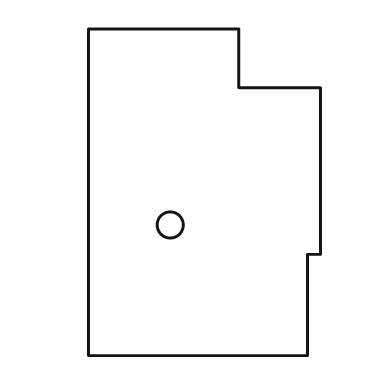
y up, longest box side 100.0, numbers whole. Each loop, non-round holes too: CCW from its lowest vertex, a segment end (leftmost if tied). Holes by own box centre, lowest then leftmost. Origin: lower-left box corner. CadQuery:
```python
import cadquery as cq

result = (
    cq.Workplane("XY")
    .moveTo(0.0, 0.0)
    .lineTo(67.0, 0.0)
    .lineTo(67.0, 31.0)
    .lineTo(71.0, 31.0)
    .lineTo(71.0, 82.0)
    .lineTo(46.0, 82.0)
    .lineTo(46.0, 100.0)
    .lineTo(0.0, 100.0)
    .close()
    .moveTo(25.0, 40.0)
    .circle(4.0)
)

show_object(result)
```